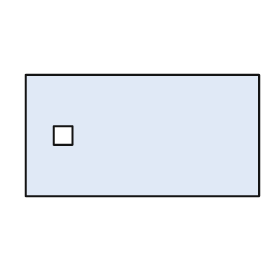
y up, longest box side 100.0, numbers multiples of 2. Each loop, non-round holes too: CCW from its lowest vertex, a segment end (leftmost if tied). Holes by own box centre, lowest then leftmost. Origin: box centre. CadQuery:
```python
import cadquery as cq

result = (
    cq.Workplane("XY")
    .moveTo(-50.0, -26.0)
    .lineTo(50.0, -26.0)
    .lineTo(50.0, 26.0)
    .lineTo(-50.0, 26.0)
    .close()
    .moveTo(-38.0, -4.0)
    .lineTo(-30.0, -4.0)
    .lineTo(-30.0, 4.0)
    .lineTo(-38.0, 4.0)
    .close()
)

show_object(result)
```